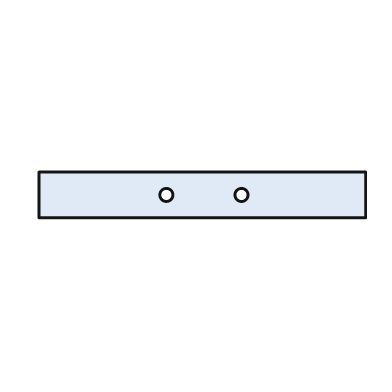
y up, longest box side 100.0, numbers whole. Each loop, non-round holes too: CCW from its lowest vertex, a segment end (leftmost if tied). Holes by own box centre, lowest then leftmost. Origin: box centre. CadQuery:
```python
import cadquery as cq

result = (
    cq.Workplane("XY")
    .moveTo(-50.0, -7.0)
    .lineTo(50.0, -7.0)
    .lineTo(50.0, 7.0)
    .lineTo(-50.0, 7.0)
    .close()
    .moveTo(-11.0, 0.0)
    .circle(2.0)
    .moveTo(12.0, 0.0)
    .circle(2.0)
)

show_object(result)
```